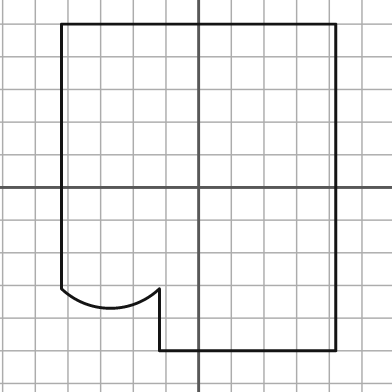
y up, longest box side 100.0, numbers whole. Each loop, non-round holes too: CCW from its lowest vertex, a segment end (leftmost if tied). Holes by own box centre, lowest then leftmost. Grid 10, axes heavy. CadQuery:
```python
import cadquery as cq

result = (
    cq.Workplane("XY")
    .moveTo(-12.0, -50.0)
    .lineTo(42.0, -50.0)
    .lineTo(42.0, 50.0)
    .lineTo(-42.0, 50.0)
    .lineTo(-42.0, -31.0)
    .threePointArc((-27.0, -37.0), (-12.0, -31.0))
    .close()
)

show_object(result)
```